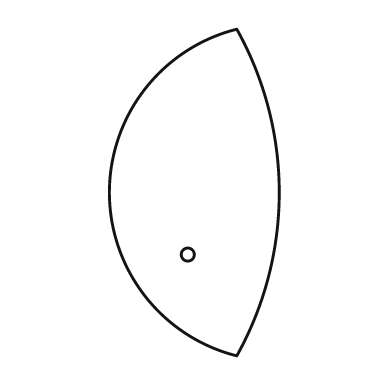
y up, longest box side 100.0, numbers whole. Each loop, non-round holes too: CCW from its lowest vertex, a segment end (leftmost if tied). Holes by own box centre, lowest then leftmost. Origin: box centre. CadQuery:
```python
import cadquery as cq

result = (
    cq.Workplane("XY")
    .moveTo(13.0, -50.0)
    .threePointArc((26.0, 0.0), (13.0, 50.0))
    .threePointArc((-26.0, 0.0), (13.0, -50.0))
    .close()
    .moveTo(-2.0, -19.0)
    .circle(2.0)
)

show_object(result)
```